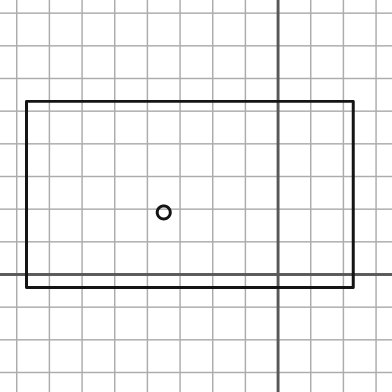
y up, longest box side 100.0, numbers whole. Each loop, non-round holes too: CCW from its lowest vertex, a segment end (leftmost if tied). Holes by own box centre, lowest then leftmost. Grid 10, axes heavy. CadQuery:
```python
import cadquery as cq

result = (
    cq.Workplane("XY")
    .moveTo(-77.0, -4.0)
    .lineTo(23.0, -4.0)
    .lineTo(23.0, 53.0)
    .lineTo(-77.0, 53.0)
    .close()
    .moveTo(-35.0, 19.0)
    .circle(2.0)
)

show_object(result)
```